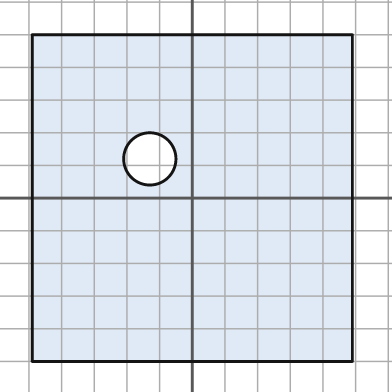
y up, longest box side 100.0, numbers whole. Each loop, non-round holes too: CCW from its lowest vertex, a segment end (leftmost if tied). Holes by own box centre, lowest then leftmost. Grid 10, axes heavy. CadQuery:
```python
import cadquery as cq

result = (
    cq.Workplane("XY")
    .moveTo(-49.0, -50.0)
    .lineTo(49.0, -50.0)
    .lineTo(49.0, 50.0)
    .lineTo(-49.0, 50.0)
    .close()
    .moveTo(-13.0, 12.0)
    .circle(8.0)
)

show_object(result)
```